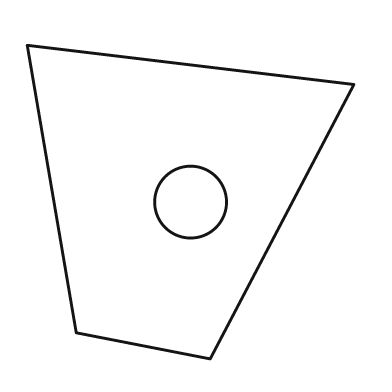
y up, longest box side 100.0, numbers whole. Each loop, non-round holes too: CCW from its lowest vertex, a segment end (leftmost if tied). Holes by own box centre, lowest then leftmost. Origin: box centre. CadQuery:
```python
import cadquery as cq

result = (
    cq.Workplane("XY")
    .moveTo(6.0, -48.0)
    .lineTo(50.0, 36.0)
    .lineTo(-50.0, 48.0)
    .lineTo(-35.0, -40.0)
    .close()
    .moveTo(0.0, 0.0)
    .circle(11.0)
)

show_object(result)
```